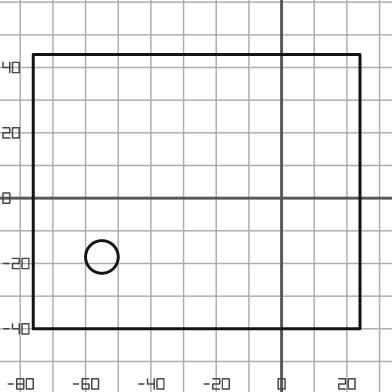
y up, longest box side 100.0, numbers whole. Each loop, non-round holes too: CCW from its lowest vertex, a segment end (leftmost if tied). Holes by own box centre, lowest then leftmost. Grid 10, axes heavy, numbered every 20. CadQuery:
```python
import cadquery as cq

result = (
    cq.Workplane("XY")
    .moveTo(-76.0, -40.0)
    .lineTo(24.0, -40.0)
    .lineTo(24.0, 44.0)
    .lineTo(-76.0, 44.0)
    .close()
    .moveTo(-55.0, -18.0)
    .circle(5.0)
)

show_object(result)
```